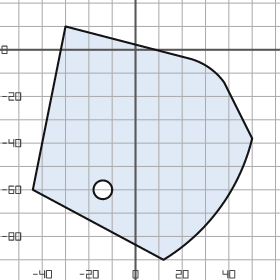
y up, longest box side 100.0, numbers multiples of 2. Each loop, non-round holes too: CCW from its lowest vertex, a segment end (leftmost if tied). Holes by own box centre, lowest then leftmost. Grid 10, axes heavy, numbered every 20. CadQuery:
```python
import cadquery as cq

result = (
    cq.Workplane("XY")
    .moveTo(12.0, -90.0)
    .threePointArc((36.0, -68.0), (50.0, -38.0))
    .lineTo(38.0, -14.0)
    .threePointArc((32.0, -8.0), (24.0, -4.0))
    .lineTo(-30.0, 10.0)
    .lineTo(-44.0, -60.0)
    .close()
    .moveTo(-14.0, -60.0)
    .circle(4.0)
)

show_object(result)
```